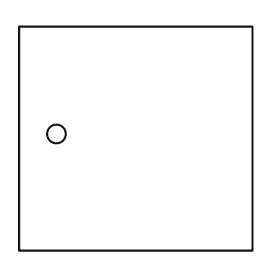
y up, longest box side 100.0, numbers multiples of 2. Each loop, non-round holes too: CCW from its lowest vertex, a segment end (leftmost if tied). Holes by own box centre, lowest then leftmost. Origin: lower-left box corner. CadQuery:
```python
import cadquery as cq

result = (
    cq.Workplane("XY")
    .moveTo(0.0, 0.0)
    .lineTo(100.0, 0.0)
    .lineTo(100.0, 96.0)
    .lineTo(0.0, 96.0)
    .close()
    .moveTo(16.0, 50.0)
    .circle(4.0)
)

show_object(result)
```